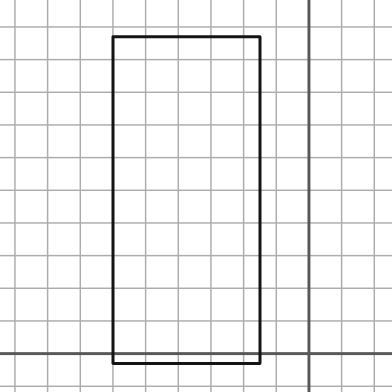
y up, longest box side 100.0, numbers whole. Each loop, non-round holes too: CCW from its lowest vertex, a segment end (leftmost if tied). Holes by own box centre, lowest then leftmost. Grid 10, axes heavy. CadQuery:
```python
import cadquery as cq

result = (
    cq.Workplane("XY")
    .moveTo(-60.0, -3.0)
    .lineTo(-15.0, -3.0)
    .lineTo(-15.0, 97.0)
    .lineTo(-60.0, 97.0)
    .close()
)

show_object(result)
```